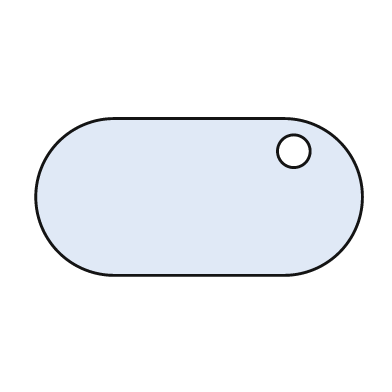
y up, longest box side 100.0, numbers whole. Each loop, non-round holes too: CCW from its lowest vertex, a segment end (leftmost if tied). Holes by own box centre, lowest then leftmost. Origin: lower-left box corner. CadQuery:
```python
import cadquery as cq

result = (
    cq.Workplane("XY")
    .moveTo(24.0, 0.0)
    .lineTo(76.0, 0.0)
    .threePointArc((100.0, 24.0), (76.0, 48.0))
    .lineTo(24.0, 48.0)
    .threePointArc((0.0, 24.0), (24.0, 0.0))
    .close()
    .moveTo(79.0, 38.0)
    .circle(5.0)
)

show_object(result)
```